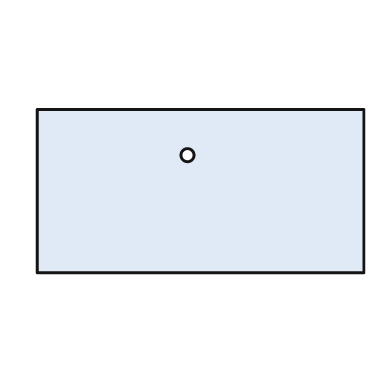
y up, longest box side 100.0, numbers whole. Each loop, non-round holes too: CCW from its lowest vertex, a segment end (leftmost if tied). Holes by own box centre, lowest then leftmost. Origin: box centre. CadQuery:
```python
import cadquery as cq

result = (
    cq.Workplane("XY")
    .moveTo(-50.0, -25.0)
    .lineTo(50.0, -25.0)
    .lineTo(50.0, 25.0)
    .lineTo(-50.0, 25.0)
    .close()
    .moveTo(-4.0, 11.0)
    .circle(2.0)
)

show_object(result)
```